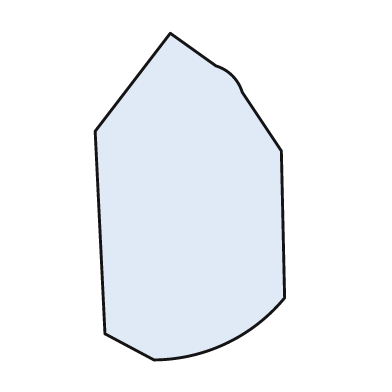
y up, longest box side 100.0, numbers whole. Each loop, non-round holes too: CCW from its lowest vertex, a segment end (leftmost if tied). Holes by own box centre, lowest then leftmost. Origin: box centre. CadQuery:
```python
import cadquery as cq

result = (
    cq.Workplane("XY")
    .moveTo(-11.0, -50.0)
    .threePointArc((11.0, -45.0), (29.0, -31.0))
    .lineTo(28.0, 14.0)
    .lineTo(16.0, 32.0)
    .threePointArc((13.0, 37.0), (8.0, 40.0))
    .lineTo(-6.0, 50.0)
    .lineTo(-29.0, 20.0)
    .lineTo(-26.0, -42.0)
    .close()
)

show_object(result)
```